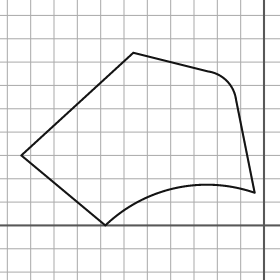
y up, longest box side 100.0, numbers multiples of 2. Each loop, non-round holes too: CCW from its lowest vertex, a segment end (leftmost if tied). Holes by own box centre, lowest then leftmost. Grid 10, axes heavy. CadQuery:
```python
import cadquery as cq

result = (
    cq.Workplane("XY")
    .moveTo(-68.0, 0.0)
    .threePointArc((-38.0, 16.0), (-4.0, 14.0))
    .lineTo(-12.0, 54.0)
    .threePointArc((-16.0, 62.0), (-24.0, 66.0))
    .lineTo(-56.0, 74.0)
    .lineTo(-104.0, 30.0)
    .close()
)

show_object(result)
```